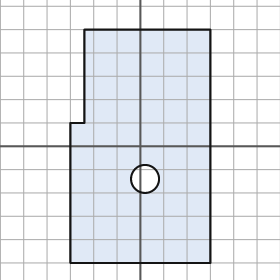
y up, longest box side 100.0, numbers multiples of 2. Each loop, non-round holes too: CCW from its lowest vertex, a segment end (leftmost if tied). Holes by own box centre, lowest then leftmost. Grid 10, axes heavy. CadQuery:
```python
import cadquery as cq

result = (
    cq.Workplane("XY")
    .moveTo(-30.0, -50.0)
    .lineTo(30.0, -50.0)
    .lineTo(30.0, 50.0)
    .lineTo(-24.0, 50.0)
    .lineTo(-24.0, 10.0)
    .lineTo(-30.0, 10.0)
    .close()
    .moveTo(2.0, -14.0)
    .circle(6.0)
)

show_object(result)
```